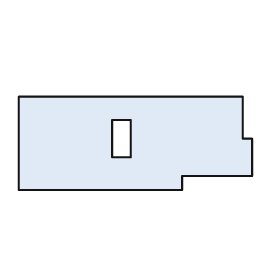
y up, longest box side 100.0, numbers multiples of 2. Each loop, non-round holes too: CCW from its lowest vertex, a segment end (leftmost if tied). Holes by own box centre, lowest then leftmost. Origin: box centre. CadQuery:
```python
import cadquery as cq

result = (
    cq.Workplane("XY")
    .moveTo(-50.0, -20.0)
    .lineTo(20.0, -20.0)
    .lineTo(20.0, -14.0)
    .lineTo(50.0, -14.0)
    .lineTo(50.0, 2.0)
    .lineTo(46.0, 2.0)
    .lineTo(46.0, 20.0)
    .lineTo(-50.0, 20.0)
    .close()
    .moveTo(-10.0, -6.0)
    .lineTo(-2.0, -6.0)
    .lineTo(-2.0, 10.0)
    .lineTo(-10.0, 10.0)
    .close()
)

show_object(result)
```